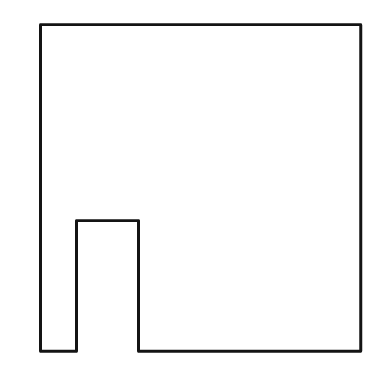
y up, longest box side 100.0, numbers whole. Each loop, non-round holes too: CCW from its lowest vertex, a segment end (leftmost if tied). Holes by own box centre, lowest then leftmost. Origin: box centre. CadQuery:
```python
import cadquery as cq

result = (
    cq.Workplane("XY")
    .moveTo(-49.0, -50.0)
    .lineTo(-38.0, -50.0)
    .lineTo(-38.0, -10.0)
    .lineTo(-19.0, -10.0)
    .lineTo(-19.0, -50.0)
    .lineTo(49.0, -50.0)
    .lineTo(49.0, 50.0)
    .lineTo(-49.0, 50.0)
    .close()
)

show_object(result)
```